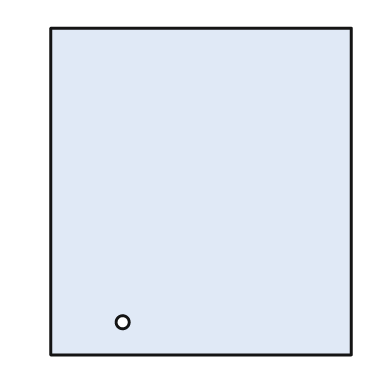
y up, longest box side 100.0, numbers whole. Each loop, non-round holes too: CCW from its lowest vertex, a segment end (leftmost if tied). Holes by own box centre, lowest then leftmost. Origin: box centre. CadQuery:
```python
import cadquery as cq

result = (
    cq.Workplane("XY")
    .moveTo(-46.0, -50.0)
    .lineTo(46.0, -50.0)
    .lineTo(46.0, 50.0)
    .lineTo(-46.0, 50.0)
    .close()
    .moveTo(-24.0, -40.0)
    .circle(2.0)
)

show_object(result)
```